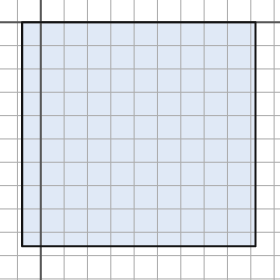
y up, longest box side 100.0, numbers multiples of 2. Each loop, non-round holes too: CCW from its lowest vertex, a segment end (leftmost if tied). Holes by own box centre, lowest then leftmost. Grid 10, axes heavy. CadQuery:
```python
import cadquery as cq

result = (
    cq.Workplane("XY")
    .moveTo(-8.0, -96.0)
    .lineTo(92.0, -96.0)
    .lineTo(92.0, 0.0)
    .lineTo(-8.0, 0.0)
    .close()
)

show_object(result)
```